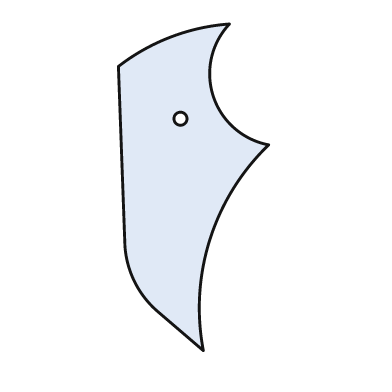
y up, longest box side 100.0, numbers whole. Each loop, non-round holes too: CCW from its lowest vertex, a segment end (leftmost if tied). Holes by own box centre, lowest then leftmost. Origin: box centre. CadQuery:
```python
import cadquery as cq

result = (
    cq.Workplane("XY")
    .moveTo(3.0, -50.0)
    .threePointArc((5.0, -16.0), (23.0, 13.0))
    .threePointArc((6.0, 28.0), (11.0, 50.0))
    .threePointArc((-7.0, 46.0), (-23.0, 37.0))
    .lineTo(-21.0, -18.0)
    .threePointArc((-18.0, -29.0), (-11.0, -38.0))
    .close()
    .moveTo(-4.0, 21.0)
    .circle(2.0)
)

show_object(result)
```